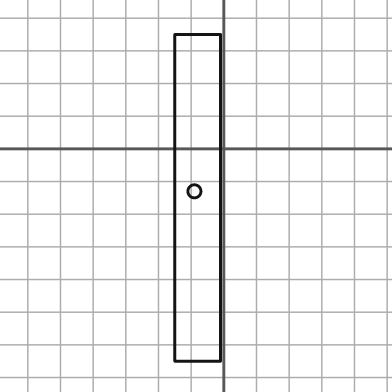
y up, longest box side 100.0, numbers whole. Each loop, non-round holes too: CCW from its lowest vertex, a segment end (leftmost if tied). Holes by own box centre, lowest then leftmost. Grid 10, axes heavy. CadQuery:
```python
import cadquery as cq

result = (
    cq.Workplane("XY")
    .moveTo(-15.0, -65.0)
    .lineTo(-1.0, -65.0)
    .lineTo(-1.0, 35.0)
    .lineTo(-15.0, 35.0)
    .close()
    .moveTo(-9.0, -13.0)
    .circle(2.0)
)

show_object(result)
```